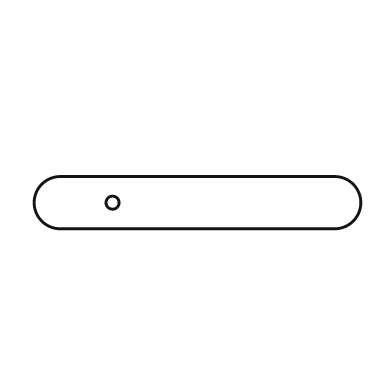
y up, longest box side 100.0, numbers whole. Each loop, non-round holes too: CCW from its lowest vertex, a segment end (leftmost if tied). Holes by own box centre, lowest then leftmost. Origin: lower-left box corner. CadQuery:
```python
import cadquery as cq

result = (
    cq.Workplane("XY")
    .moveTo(8.0, 0.0)
    .lineTo(92.0, 0.0)
    .threePointArc((100.0, 8.0), (92.0, 16.0))
    .lineTo(8.0, 16.0)
    .threePointArc((0.0, 8.0), (8.0, 0.0))
    .close()
    .moveTo(24.0, 8.0)
    .circle(2.0)
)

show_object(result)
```